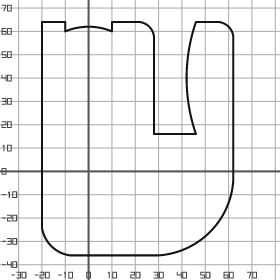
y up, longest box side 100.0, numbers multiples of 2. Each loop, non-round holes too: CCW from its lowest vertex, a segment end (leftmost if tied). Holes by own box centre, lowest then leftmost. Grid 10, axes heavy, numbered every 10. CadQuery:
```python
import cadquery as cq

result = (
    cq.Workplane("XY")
    .moveTo(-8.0, -36.0)
    .lineTo(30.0, -36.0)
    .threePointArc((52.0, -26.0), (62.0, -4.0))
    .lineTo(62.0, 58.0)
    .threePointArc((60.0, 62.0), (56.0, 64.0))
    .lineTo(46.0, 64.0)
    .threePointArc((42.0, 40.0), (46.0, 16.0))
    .lineTo(28.0, 16.0)
    .lineTo(28.0, 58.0)
    .threePointArc((26.0, 62.0), (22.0, 64.0))
    .lineTo(10.0, 64.0)
    .lineTo(10.0, 60.0)
    .threePointArc((0.0, 62.0), (-10.0, 60.0))
    .lineTo(-10.0, 64.0)
    .lineTo(-20.0, 64.0)
    .lineTo(-20.0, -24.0)
    .threePointArc((-16.0, -32.0), (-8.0, -36.0))
    .close()
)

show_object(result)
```